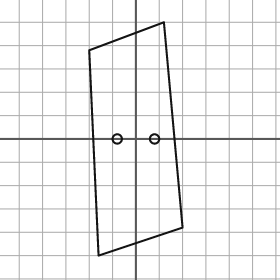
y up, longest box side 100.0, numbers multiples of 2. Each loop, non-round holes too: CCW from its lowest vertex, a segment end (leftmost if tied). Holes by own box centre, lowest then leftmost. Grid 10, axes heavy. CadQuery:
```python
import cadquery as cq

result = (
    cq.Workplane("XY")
    .moveTo(-16.0, -50.0)
    .lineTo(20.0, -38.0)
    .lineTo(12.0, 50.0)
    .lineTo(-20.0, 38.0)
    .close()
    .moveTo(-8.0, 0.0)
    .circle(2.0)
    .moveTo(8.0, 0.0)
    .circle(2.0)
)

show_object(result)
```